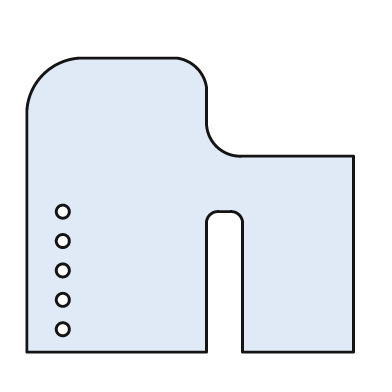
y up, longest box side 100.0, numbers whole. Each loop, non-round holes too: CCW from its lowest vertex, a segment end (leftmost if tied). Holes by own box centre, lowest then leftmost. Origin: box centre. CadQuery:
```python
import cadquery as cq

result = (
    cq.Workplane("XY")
    .moveTo(-50.0, -45.0)
    .lineTo(5.0, -45.0)
    .lineTo(5.0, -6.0)
    .threePointArc((6.0, -3.0), (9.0, -2.0))
    .lineTo(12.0, -2.0)
    .threePointArc((15.0, -3.0), (16.0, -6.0))
    .lineTo(16.0, -45.0)
    .lineTo(50.0, -45.0)
    .lineTo(50.0, 15.0)
    .lineTo(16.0, 15.0)
    .threePointArc((8.0, 18.0), (5.0, 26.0))
    .lineTo(5.0, 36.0)
    .threePointArc((2.0, 42.0), (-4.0, 45.0))
    .lineTo(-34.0, 45.0)
    .threePointArc((-45.0, 40.0), (-50.0, 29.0))
    .close()
    .moveTo(-39.0, -38.0)
    .circle(2.0)
    .moveTo(-39.0, -29.0)
    .circle(2.0)
    .moveTo(-39.0, -20.0)
    .circle(2.0)
    .moveTo(-39.0, -11.0)
    .circle(2.0)
    .moveTo(-39.0, -2.0)
    .circle(2.0)
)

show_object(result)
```